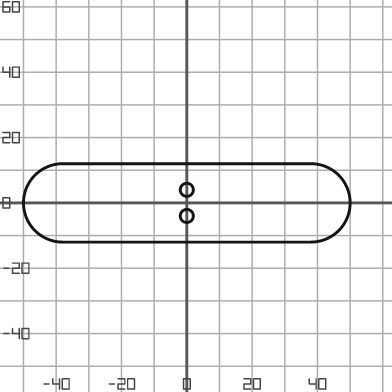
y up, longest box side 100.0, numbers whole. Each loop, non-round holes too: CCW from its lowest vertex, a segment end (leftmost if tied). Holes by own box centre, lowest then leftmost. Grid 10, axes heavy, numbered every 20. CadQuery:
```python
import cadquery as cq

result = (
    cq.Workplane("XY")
    .moveTo(-38.0, -12.0)
    .lineTo(38.0, -12.0)
    .threePointArc((50.0, 0.0), (38.0, 12.0))
    .lineTo(-38.0, 12.0)
    .threePointArc((-50.0, 0.0), (-38.0, -12.0))
    .close()
    .moveTo(0.0, -4.0)
    .circle(2.0)
    .moveTo(0.0, 4.0)
    .circle(2.0)
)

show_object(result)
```